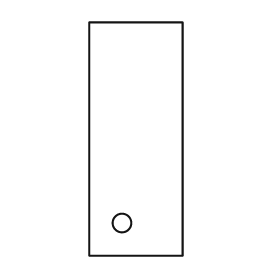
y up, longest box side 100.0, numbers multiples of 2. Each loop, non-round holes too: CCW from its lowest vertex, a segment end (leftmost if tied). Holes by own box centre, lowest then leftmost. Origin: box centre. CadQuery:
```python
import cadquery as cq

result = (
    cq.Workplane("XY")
    .moveTo(-20.0, -50.0)
    .lineTo(20.0, -50.0)
    .lineTo(20.0, 50.0)
    .lineTo(-20.0, 50.0)
    .close()
    .moveTo(-6.0, -36.0)
    .circle(4.0)
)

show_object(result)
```